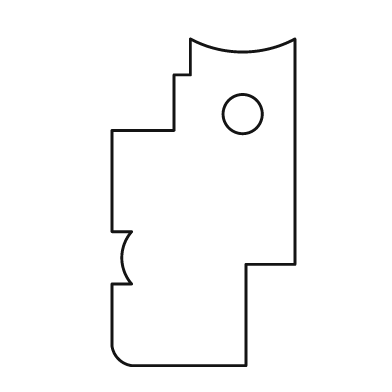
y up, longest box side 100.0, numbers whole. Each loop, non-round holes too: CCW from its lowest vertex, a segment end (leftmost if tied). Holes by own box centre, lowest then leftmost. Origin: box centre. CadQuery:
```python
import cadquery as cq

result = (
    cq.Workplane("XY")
    .moveTo(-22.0, -50.0)
    .lineTo(13.0, -50.0)
    .lineTo(13.0, -19.0)
    .lineTo(28.0, -19.0)
    .lineTo(28.0, 50.0)
    .threePointArc((12.0, 46.0), (-4.0, 50.0))
    .lineTo(-4.0, 39.0)
    .lineTo(-9.0, 39.0)
    .lineTo(-9.0, 22.0)
    .lineTo(-28.0, 22.0)
    .lineTo(-28.0, -9.0)
    .lineTo(-22.0, -9.0)
    .threePointArc((-25.0, -17.0), (-22.0, -25.0))
    .lineTo(-28.0, -25.0)
    .lineTo(-28.0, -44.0)
    .threePointArc((-26.0, -48.0), (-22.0, -50.0))
    .close()
    .moveTo(12.0, 27.0)
    .circle(6.0)
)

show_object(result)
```